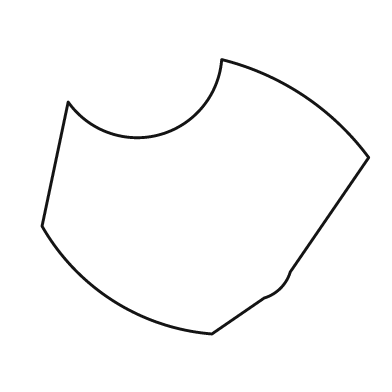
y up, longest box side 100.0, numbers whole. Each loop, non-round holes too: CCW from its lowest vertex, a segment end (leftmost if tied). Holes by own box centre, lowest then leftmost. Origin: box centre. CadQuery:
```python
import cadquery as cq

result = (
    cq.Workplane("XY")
    .moveTo(2.0, -42.0)
    .lineTo(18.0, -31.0)
    .threePointArc((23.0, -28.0), (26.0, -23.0))
    .lineTo(50.0, 12.0)
    .threePointArc((30.0, 31.0), (5.0, 42.0))
    .threePointArc((-14.0, 19.0), (-42.0, 29.0))
    .lineTo(-50.0, -9.0)
    .threePointArc((-28.0, -32.0), (2.0, -42.0))
    .close()
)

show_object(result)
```